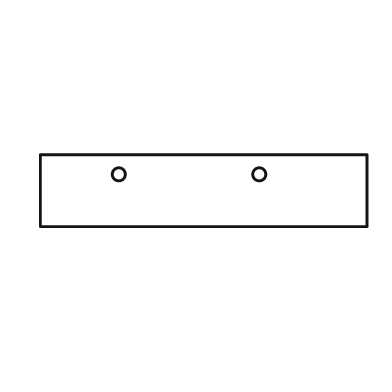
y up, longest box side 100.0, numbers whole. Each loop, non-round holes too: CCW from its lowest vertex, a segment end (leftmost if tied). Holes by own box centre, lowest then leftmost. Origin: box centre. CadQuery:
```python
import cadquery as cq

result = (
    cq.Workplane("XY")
    .moveTo(-50.0, -11.0)
    .lineTo(50.0, -11.0)
    .lineTo(50.0, 11.0)
    .lineTo(-50.0, 11.0)
    .close()
    .moveTo(-26.0, 5.0)
    .circle(2.0)
    .moveTo(17.0, 5.0)
    .circle(2.0)
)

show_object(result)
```